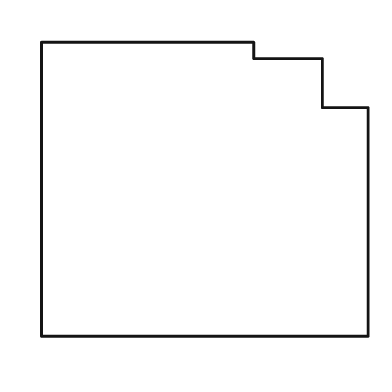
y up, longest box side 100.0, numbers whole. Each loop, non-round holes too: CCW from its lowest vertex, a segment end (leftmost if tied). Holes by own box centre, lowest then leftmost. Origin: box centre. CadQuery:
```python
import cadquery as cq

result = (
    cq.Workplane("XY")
    .moveTo(-50.0, -45.0)
    .lineTo(50.0, -45.0)
    .lineTo(50.0, 25.0)
    .lineTo(36.0, 25.0)
    .lineTo(36.0, 40.0)
    .lineTo(15.0, 40.0)
    .lineTo(15.0, 45.0)
    .lineTo(-50.0, 45.0)
    .close()
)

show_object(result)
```